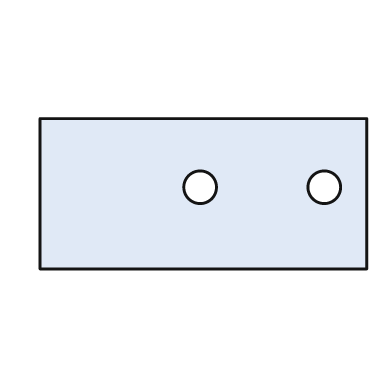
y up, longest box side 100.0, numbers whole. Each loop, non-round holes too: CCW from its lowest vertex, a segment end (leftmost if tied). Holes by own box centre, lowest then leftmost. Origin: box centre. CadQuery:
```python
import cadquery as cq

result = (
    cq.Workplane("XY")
    .moveTo(-50.0, -23.0)
    .lineTo(50.0, -23.0)
    .lineTo(50.0, 23.0)
    .lineTo(-50.0, 23.0)
    .close()
    .moveTo(-1.0, 2.0)
    .circle(5.0)
    .moveTo(37.0, 2.0)
    .circle(5.0)
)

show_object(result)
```